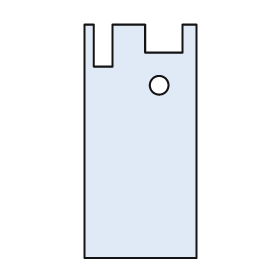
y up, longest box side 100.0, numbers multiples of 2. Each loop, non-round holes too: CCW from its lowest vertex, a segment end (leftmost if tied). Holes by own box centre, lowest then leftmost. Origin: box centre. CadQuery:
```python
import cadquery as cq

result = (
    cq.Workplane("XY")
    .moveTo(-24.0, -50.0)
    .lineTo(24.0, -50.0)
    .lineTo(24.0, 50.0)
    .lineTo(18.0, 50.0)
    .lineTo(18.0, 38.0)
    .lineTo(2.0, 38.0)
    .lineTo(2.0, 50.0)
    .lineTo(-12.0, 50.0)
    .lineTo(-12.0, 32.0)
    .lineTo(-20.0, 32.0)
    .lineTo(-20.0, 50.0)
    .lineTo(-24.0, 50.0)
    .close()
    .moveTo(8.0, 24.0)
    .circle(4.0)
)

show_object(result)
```